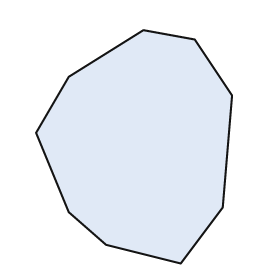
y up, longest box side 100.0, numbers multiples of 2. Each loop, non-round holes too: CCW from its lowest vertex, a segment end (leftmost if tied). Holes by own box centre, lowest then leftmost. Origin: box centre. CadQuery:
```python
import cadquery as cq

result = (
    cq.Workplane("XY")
    .moveTo(20.0, -50.0)
    .lineTo(38.0, -26.0)
    .lineTo(42.0, 22.0)
    .lineTo(26.0, 46.0)
    .lineTo(4.0, 50.0)
    .lineTo(-28.0, 30.0)
    .lineTo(-42.0, 6.0)
    .lineTo(-28.0, -28.0)
    .lineTo(-12.0, -42.0)
    .close()
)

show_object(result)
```